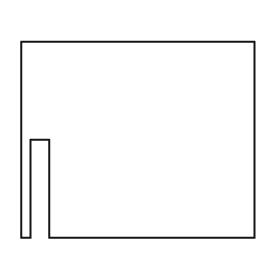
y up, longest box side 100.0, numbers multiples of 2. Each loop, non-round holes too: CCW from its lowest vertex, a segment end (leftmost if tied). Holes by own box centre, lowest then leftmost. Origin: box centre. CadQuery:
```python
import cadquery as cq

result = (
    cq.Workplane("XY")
    .moveTo(-50.0, -42.0)
    .lineTo(-46.0, -42.0)
    .lineTo(-46.0, 0.0)
    .lineTo(-38.0, 0.0)
    .lineTo(-38.0, -42.0)
    .lineTo(50.0, -42.0)
    .lineTo(50.0, 42.0)
    .lineTo(-50.0, 42.0)
    .close()
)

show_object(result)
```